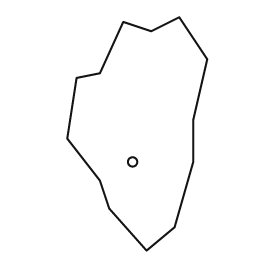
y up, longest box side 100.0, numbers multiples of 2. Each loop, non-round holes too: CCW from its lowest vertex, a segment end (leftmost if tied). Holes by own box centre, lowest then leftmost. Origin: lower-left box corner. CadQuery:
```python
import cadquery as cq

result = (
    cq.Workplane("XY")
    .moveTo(34.0, 0.0)
    .lineTo(46.0, 10.0)
    .lineTo(54.0, 38.0)
    .lineTo(54.0, 56.0)
    .lineTo(60.0, 82.0)
    .lineTo(48.0, 100.0)
    .lineTo(36.0, 94.0)
    .lineTo(24.0, 98.0)
    .lineTo(14.0, 76.0)
    .lineTo(4.0, 74.0)
    .lineTo(0.0, 48.0)
    .lineTo(14.0, 30.0)
    .lineTo(18.0, 18.0)
    .close()
    .moveTo(28.0, 38.0)
    .circle(2.0)
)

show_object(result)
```